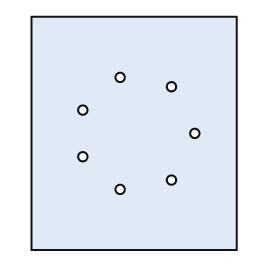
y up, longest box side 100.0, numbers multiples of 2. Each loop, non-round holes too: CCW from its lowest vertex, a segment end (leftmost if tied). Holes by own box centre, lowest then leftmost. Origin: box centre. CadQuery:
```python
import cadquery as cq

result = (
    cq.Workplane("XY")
    .moveTo(-44.0, -50.0)
    .lineTo(44.0, -50.0)
    .lineTo(44.0, 50.0)
    .lineTo(-44.0, 50.0)
    .close()
    .moveTo(-6.0, -24.0)
    .circle(2.0)
    .moveTo(16.0, -20.0)
    .circle(2.0)
    .moveTo(-22.0, -10.0)
    .circle(2.0)
    .moveTo(26.0, 0.0)
    .circle(2.0)
    .moveTo(-22.0, 10.0)
    .circle(2.0)
    .moveTo(16.0, 20.0)
    .circle(2.0)
    .moveTo(-6.0, 24.0)
    .circle(2.0)
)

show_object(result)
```